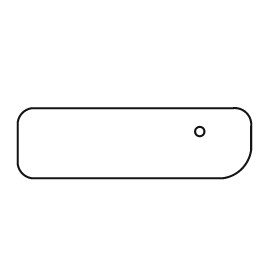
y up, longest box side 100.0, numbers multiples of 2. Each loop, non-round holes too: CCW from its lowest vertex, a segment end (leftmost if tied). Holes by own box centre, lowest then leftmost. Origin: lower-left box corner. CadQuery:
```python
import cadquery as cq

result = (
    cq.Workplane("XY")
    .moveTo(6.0, 0.0)
    .lineTo(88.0, 0.0)
    .threePointArc((96.0, 4.0), (100.0, 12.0))
    .lineTo(100.0, 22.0)
    .threePointArc((98.0, 28.0), (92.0, 30.0))
    .lineTo(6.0, 30.0)
    .threePointArc((2.0, 28.0), (0.0, 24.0))
    .lineTo(0.0, 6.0)
    .threePointArc((2.0, 2.0), (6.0, 0.0))
    .close()
    .moveTo(78.0, 20.0)
    .circle(2.0)
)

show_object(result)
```